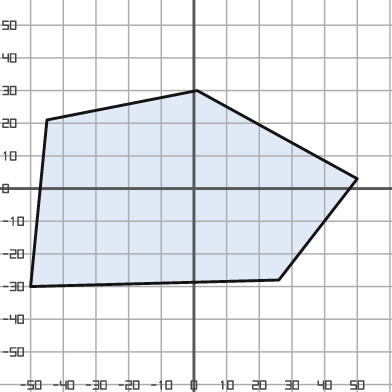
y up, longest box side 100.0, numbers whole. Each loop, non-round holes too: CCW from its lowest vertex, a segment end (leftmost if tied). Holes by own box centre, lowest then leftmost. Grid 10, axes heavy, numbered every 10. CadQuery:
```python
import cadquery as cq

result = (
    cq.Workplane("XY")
    .moveTo(-50.0, -30.0)
    .lineTo(26.0, -28.0)
    .lineTo(50.0, 3.0)
    .lineTo(1.0, 30.0)
    .lineTo(-45.0, 21.0)
    .close()
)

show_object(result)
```